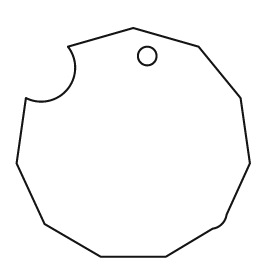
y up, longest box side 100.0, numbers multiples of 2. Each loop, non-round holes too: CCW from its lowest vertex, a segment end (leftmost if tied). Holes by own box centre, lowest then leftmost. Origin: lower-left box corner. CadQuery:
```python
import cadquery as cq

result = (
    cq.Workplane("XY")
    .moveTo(36.0, 0.0)
    .lineTo(64.0, 0.0)
    .lineTo(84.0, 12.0)
    .threePointArc((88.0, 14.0), (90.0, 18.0))
    .lineTo(100.0, 40.0)
    .lineTo(96.0, 68.0)
    .lineTo(78.0, 90.0)
    .lineTo(50.0, 98.0)
    .lineTo(22.0, 90.0)
    .threePointArc((22.0, 72.0), (4.0, 68.0))
    .lineTo(0.0, 40.0)
    .lineTo(12.0, 14.0)
    .close()
    .moveTo(56.0, 86.0)
    .circle(4.0)
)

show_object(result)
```